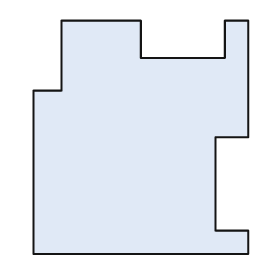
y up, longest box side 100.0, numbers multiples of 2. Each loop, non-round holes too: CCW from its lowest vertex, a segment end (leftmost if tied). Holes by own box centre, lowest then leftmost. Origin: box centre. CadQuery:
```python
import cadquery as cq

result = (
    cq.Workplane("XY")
    .moveTo(-46.0, -50.0)
    .lineTo(46.0, -50.0)
    .lineTo(46.0, -40.0)
    .lineTo(32.0, -40.0)
    .lineTo(32.0, 0.0)
    .lineTo(46.0, 0.0)
    .lineTo(46.0, 50.0)
    .lineTo(36.0, 50.0)
    .lineTo(36.0, 34.0)
    .lineTo(0.0, 34.0)
    .lineTo(0.0, 50.0)
    .lineTo(-34.0, 50.0)
    .lineTo(-34.0, 20.0)
    .lineTo(-46.0, 20.0)
    .close()
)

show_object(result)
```